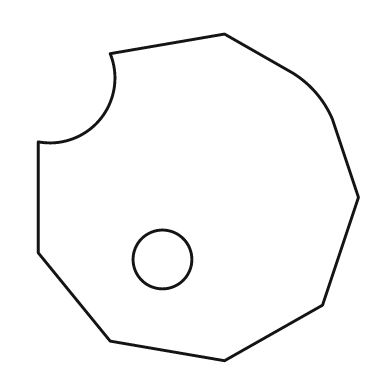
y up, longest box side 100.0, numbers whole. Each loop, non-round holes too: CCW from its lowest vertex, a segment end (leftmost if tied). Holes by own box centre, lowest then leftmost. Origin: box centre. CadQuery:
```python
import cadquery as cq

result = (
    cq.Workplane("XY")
    .moveTo(8.0, -50.0)
    .lineTo(38.0, -33.0)
    .lineTo(49.0, 0.0)
    .lineTo(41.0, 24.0)
    .threePointArc((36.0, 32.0), (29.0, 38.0))
    .lineTo(8.0, 50.0)
    .lineTo(-27.0, 44.0)
    .threePointArc((-30.0, 24.0), (-49.0, 17.0))
    .lineTo(-49.0, -17.0)
    .lineTo(-27.0, -44.0)
    .close()
    .moveTo(-11.0, -19.0)
    .circle(9.0)
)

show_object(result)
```